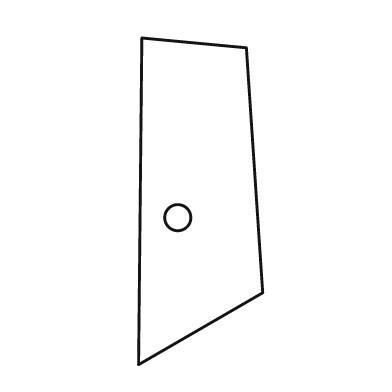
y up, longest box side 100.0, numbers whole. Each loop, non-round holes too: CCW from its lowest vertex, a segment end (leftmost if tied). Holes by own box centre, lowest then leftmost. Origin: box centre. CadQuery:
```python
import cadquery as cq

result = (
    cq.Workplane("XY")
    .moveTo(-19.0, -50.0)
    .lineTo(19.0, -28.0)
    .lineTo(14.0, 47.0)
    .lineTo(-18.0, 50.0)
    .close()
    .moveTo(-7.0, -5.0)
    .circle(4.0)
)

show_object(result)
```